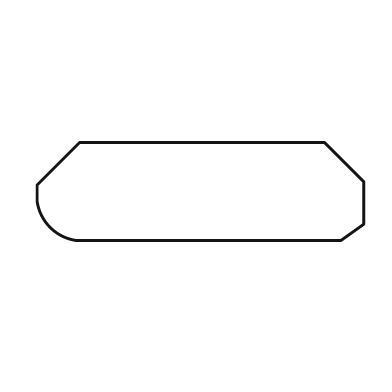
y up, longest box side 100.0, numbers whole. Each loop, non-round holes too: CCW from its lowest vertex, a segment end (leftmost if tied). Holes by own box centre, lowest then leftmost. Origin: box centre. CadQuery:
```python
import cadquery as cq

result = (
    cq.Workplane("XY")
    .moveTo(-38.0, -15.0)
    .lineTo(43.0, -15.0)
    .lineTo(50.0, -10.0)
    .lineTo(50.0, 3.0)
    .lineTo(38.0, 15.0)
    .lineTo(-37.0, 15.0)
    .lineTo(-50.0, 2.0)
    .lineTo(-50.0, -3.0)
    .threePointArc((-46.0, -11.0), (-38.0, -15.0))
    .close()
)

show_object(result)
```